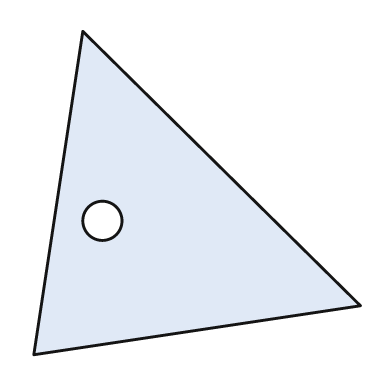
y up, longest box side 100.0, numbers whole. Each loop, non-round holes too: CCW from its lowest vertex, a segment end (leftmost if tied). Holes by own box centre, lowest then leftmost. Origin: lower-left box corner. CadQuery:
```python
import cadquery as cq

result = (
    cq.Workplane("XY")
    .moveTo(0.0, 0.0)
    .lineTo(100.0, 15.0)
    .lineTo(15.0, 99.0)
    .close()
    .moveTo(21.0, 41.0)
    .circle(6.0)
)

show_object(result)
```